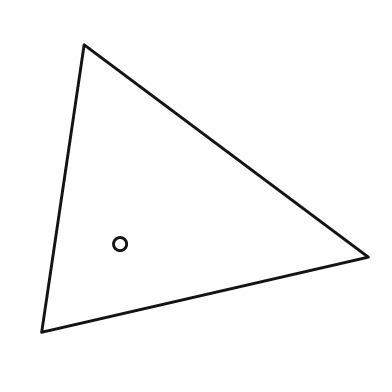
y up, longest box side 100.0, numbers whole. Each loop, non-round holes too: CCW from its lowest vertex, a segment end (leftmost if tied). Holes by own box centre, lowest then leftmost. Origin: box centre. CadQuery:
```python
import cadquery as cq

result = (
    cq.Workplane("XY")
    .moveTo(-50.0, -44.0)
    .lineTo(50.0, -21.0)
    .lineTo(-37.0, 44.0)
    .close()
    .moveTo(-26.0, -17.0)
    .circle(2.0)
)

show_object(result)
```